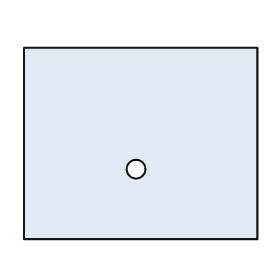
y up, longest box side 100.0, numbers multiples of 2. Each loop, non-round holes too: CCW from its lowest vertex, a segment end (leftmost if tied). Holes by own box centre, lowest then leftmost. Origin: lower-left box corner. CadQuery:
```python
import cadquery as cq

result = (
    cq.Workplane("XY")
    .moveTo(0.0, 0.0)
    .lineTo(100.0, 0.0)
    .lineTo(100.0, 82.0)
    .lineTo(0.0, 82.0)
    .close()
    .moveTo(48.0, 30.0)
    .circle(4.0)
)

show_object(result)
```